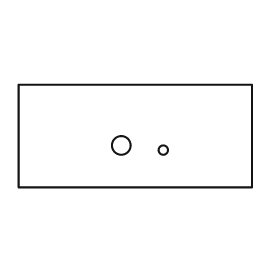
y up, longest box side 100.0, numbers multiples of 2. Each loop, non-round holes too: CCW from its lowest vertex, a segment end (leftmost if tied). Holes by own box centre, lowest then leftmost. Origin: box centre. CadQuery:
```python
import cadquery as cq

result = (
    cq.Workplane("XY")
    .moveTo(-50.0, -22.0)
    .lineTo(50.0, -22.0)
    .lineTo(50.0, 22.0)
    .lineTo(-50.0, 22.0)
    .close()
    .moveTo(12.0, -6.0)
    .circle(2.0)
    .moveTo(-6.0, -4.0)
    .circle(4.0)
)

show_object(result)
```